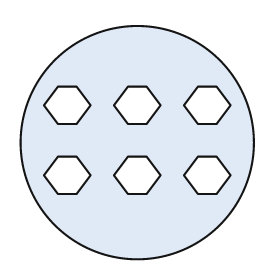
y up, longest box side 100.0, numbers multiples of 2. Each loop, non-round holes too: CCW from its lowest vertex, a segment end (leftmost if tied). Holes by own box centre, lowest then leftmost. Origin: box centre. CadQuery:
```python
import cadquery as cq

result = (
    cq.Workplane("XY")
    .moveTo(0.0, 0.0)
    .circle(50.0)
    .moveTo(-34.0, -22.0)
    .lineTo(-26.0, -22.0)
    .lineTo(-20.0, -14.0)
    .lineTo(-26.0, -6.0)
    .lineTo(-34.0, -6.0)
    .lineTo(-40.0, -14.0)
    .close()
    .moveTo(-4.0, -22.0)
    .lineTo(4.0, -22.0)
    .lineTo(10.0, -14.0)
    .lineTo(4.0, -6.0)
    .lineTo(-4.0, -6.0)
    .lineTo(-10.0, -14.0)
    .close()
    .moveTo(26.0, -22.0)
    .lineTo(34.0, -22.0)
    .lineTo(40.0, -14.0)
    .lineTo(34.0, -6.0)
    .lineTo(26.0, -6.0)
    .lineTo(20.0, -14.0)
    .close()
    .moveTo(-34.0, 8.0)
    .lineTo(-26.0, 8.0)
    .lineTo(-20.0, 16.0)
    .lineTo(-26.0, 24.0)
    .lineTo(-34.0, 24.0)
    .lineTo(-40.0, 16.0)
    .close()
    .moveTo(-4.0, 8.0)
    .lineTo(4.0, 8.0)
    .lineTo(10.0, 16.0)
    .lineTo(4.0, 24.0)
    .lineTo(-4.0, 24.0)
    .lineTo(-10.0, 16.0)
    .close()
    .moveTo(26.0, 8.0)
    .lineTo(34.0, 8.0)
    .lineTo(40.0, 16.0)
    .lineTo(34.0, 24.0)
    .lineTo(26.0, 24.0)
    .lineTo(20.0, 16.0)
    .close()
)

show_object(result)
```